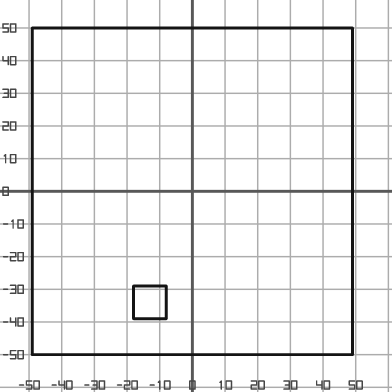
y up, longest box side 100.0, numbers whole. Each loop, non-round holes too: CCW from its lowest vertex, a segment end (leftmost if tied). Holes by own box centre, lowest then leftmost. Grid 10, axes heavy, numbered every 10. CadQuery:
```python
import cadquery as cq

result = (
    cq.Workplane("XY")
    .moveTo(-49.0, -50.0)
    .lineTo(49.0, -50.0)
    .lineTo(49.0, 50.0)
    .lineTo(-49.0, 50.0)
    .close()
    .moveTo(-18.0, -39.0)
    .lineTo(-8.0, -39.0)
    .lineTo(-8.0, -29.0)
    .lineTo(-18.0, -29.0)
    .close()
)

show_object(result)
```